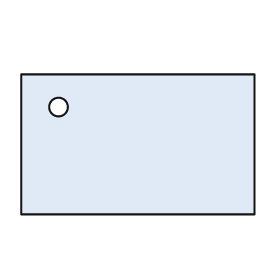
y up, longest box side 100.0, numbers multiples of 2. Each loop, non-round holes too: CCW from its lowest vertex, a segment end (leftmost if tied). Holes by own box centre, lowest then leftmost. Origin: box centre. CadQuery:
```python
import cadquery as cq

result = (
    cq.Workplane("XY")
    .moveTo(-50.0, -30.0)
    .lineTo(50.0, -30.0)
    .lineTo(50.0, 30.0)
    .lineTo(-50.0, 30.0)
    .close()
    .moveTo(-34.0, 16.0)
    .circle(4.0)
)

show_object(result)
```